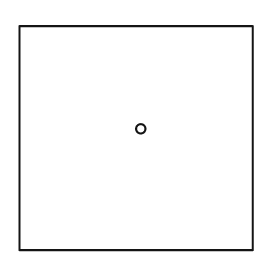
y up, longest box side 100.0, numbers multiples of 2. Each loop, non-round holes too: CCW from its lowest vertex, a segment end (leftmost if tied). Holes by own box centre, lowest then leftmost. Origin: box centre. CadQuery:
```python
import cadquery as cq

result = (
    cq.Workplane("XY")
    .moveTo(-50.0, -48.0)
    .lineTo(50.0, -48.0)
    .lineTo(50.0, 48.0)
    .lineTo(-50.0, 48.0)
    .close()
    .moveTo(2.0, 4.0)
    .circle(2.0)
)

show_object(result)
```